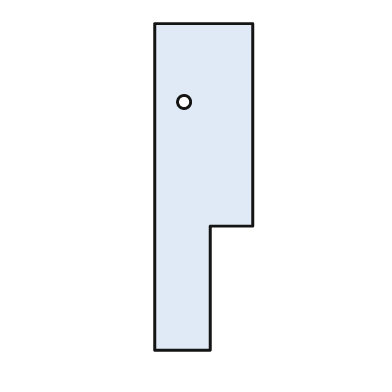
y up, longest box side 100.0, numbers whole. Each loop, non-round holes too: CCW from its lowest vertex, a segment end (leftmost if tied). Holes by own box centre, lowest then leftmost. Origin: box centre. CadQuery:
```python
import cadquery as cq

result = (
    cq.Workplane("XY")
    .moveTo(-15.0, -50.0)
    .lineTo(2.0, -50.0)
    .lineTo(2.0, -12.0)
    .lineTo(15.0, -12.0)
    .lineTo(15.0, 50.0)
    .lineTo(-15.0, 50.0)
    .close()
    .moveTo(-6.0, 26.0)
    .circle(2.0)
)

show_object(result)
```